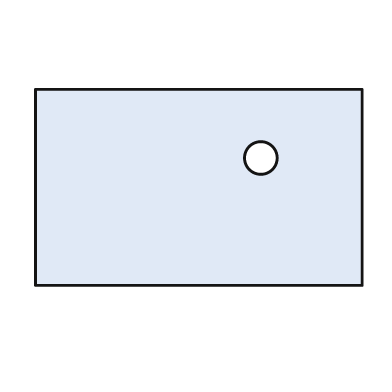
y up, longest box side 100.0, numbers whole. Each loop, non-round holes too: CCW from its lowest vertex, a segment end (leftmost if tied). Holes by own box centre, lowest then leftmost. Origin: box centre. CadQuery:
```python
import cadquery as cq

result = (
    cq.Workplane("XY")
    .moveTo(-50.0, -30.0)
    .lineTo(50.0, -30.0)
    .lineTo(50.0, 30.0)
    .lineTo(-50.0, 30.0)
    .close()
    .moveTo(19.0, 9.0)
    .circle(5.0)
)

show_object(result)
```